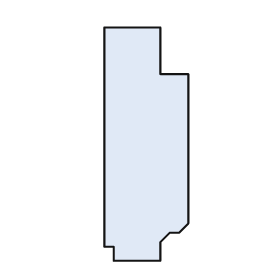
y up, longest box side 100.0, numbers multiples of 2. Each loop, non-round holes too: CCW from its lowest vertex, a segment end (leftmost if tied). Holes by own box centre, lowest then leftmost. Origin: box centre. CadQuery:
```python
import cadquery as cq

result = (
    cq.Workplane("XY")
    .moveTo(-14.0, -50.0)
    .lineTo(6.0, -50.0)
    .lineTo(6.0, -42.0)
    .lineTo(10.0, -38.0)
    .lineTo(14.0, -38.0)
    .lineTo(18.0, -34.0)
    .lineTo(18.0, 30.0)
    .lineTo(6.0, 30.0)
    .lineTo(6.0, 50.0)
    .lineTo(-18.0, 50.0)
    .lineTo(-18.0, -44.0)
    .lineTo(-14.0, -44.0)
    .close()
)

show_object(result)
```